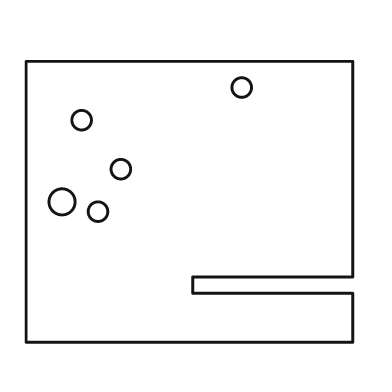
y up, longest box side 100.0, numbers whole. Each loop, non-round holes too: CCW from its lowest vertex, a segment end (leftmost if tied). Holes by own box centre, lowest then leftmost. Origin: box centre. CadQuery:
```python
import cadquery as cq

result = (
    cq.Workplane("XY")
    .moveTo(-50.0, -43.0)
    .lineTo(50.0, -43.0)
    .lineTo(50.0, -28.0)
    .lineTo(1.0, -28.0)
    .lineTo(1.0, -23.0)
    .lineTo(50.0, -23.0)
    .lineTo(50.0, 43.0)
    .lineTo(-50.0, 43.0)
    .close()
    .moveTo(-28.0, -3.0)
    .circle(3.0)
    .moveTo(-39.0, 0.0)
    .circle(4.0)
    .moveTo(-21.0, 10.0)
    .circle(3.0)
    .moveTo(-33.0, 25.0)
    .circle(3.0)
    .moveTo(16.0, 35.0)
    .circle(3.0)
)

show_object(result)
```